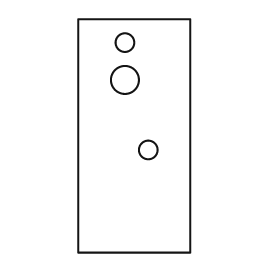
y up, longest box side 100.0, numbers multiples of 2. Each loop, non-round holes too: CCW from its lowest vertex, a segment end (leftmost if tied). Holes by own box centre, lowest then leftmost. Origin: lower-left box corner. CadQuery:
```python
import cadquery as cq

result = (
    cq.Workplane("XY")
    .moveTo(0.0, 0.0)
    .lineTo(48.0, 0.0)
    .lineTo(48.0, 100.0)
    .lineTo(0.0, 100.0)
    .close()
    .moveTo(30.0, 44.0)
    .circle(4.0)
    .moveTo(20.0, 74.0)
    .circle(6.0)
    .moveTo(20.0, 90.0)
    .circle(4.0)
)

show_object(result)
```